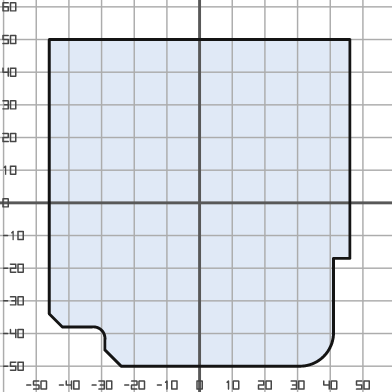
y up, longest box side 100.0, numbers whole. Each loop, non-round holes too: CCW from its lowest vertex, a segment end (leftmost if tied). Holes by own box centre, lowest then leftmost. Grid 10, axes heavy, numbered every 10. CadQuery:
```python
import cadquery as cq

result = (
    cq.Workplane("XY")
    .moveTo(-24.0, -50.0)
    .lineTo(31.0, -50.0)
    .threePointArc((38.0, -47.0), (41.0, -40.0))
    .lineTo(41.0, -17.0)
    .lineTo(46.0, -17.0)
    .lineTo(46.0, 50.0)
    .lineTo(-46.0, 50.0)
    .lineTo(-46.0, -34.0)
    .lineTo(-42.0, -38.0)
    .lineTo(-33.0, -38.0)
    .threePointArc((-30.0, -39.0), (-29.0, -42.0))
    .lineTo(-29.0, -45.0)
    .close()
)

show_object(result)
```